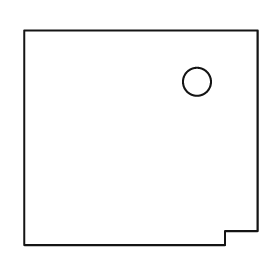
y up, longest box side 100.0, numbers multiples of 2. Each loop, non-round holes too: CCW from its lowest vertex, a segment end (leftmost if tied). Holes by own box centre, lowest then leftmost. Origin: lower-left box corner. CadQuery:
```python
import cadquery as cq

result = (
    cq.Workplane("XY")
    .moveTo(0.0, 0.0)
    .lineTo(86.0, 0.0)
    .lineTo(86.0, 6.0)
    .lineTo(100.0, 6.0)
    .lineTo(100.0, 92.0)
    .lineTo(0.0, 92.0)
    .close()
    .moveTo(74.0, 70.0)
    .circle(6.0)
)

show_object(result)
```